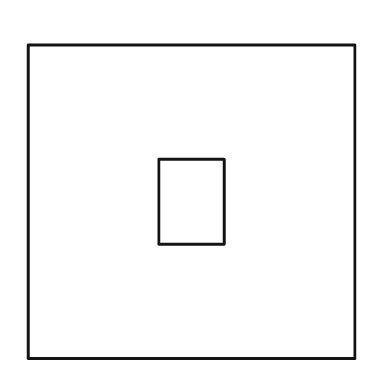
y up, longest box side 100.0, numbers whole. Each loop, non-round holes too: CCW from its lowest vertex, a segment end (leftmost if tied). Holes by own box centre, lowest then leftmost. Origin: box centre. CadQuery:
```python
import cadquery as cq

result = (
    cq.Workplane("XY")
    .moveTo(-50.0, -48.0)
    .lineTo(50.0, -48.0)
    .lineTo(50.0, 48.0)
    .lineTo(-50.0, 48.0)
    .close()
    .moveTo(-10.0, -13.0)
    .lineTo(10.0, -13.0)
    .lineTo(10.0, 13.0)
    .lineTo(-10.0, 13.0)
    .close()
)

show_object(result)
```